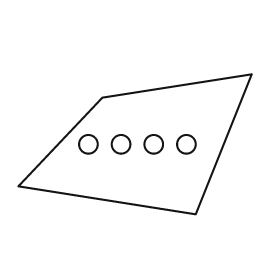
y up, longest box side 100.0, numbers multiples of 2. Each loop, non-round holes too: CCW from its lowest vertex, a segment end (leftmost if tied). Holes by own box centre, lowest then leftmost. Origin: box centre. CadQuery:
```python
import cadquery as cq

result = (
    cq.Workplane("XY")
    .moveTo(26.0, -30.0)
    .lineTo(50.0, 30.0)
    .lineTo(-14.0, 20.0)
    .lineTo(-50.0, -18.0)
    .close()
    .moveTo(-20.0, 0.0)
    .circle(4.0)
    .moveTo(-6.0, 0.0)
    .circle(4.0)
    .moveTo(8.0, 0.0)
    .circle(4.0)
    .moveTo(22.0, 0.0)
    .circle(4.0)
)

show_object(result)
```